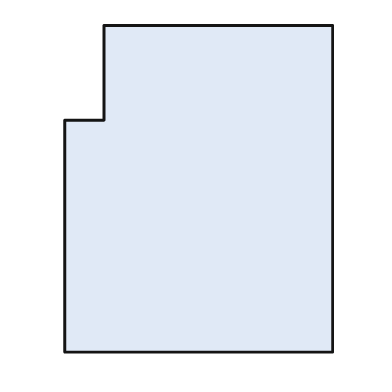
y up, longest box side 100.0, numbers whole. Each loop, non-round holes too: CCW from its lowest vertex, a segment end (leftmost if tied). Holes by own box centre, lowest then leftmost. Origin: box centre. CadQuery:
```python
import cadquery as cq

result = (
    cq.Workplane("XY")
    .moveTo(-41.0, -50.0)
    .lineTo(41.0, -50.0)
    .lineTo(41.0, 50.0)
    .lineTo(-29.0, 50.0)
    .lineTo(-29.0, 21.0)
    .lineTo(-41.0, 21.0)
    .close()
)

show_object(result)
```